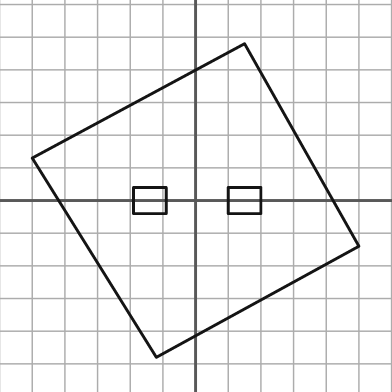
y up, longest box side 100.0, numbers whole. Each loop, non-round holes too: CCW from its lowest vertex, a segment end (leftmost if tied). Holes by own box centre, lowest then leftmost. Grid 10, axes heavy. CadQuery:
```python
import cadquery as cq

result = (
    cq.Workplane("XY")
    .moveTo(-12.0, -48.0)
    .lineTo(50.0, -14.0)
    .lineTo(15.0, 48.0)
    .lineTo(-50.0, 13.0)
    .close()
    .moveTo(-19.0, -4.0)
    .lineTo(-9.0, -4.0)
    .lineTo(-9.0, 4.0)
    .lineTo(-19.0, 4.0)
    .close()
    .moveTo(10.0, -4.0)
    .lineTo(20.0, -4.0)
    .lineTo(20.0, 4.0)
    .lineTo(10.0, 4.0)
    .close()
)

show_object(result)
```